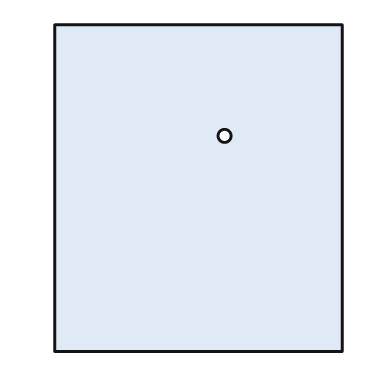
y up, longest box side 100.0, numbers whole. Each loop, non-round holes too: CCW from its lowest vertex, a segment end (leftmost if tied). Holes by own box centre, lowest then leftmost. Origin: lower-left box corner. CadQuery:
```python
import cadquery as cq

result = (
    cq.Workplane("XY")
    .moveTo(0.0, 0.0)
    .lineTo(88.0, 0.0)
    .lineTo(88.0, 100.0)
    .lineTo(0.0, 100.0)
    .close()
    .moveTo(52.0, 66.0)
    .circle(2.0)
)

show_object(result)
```